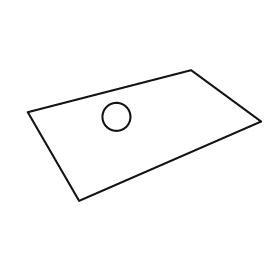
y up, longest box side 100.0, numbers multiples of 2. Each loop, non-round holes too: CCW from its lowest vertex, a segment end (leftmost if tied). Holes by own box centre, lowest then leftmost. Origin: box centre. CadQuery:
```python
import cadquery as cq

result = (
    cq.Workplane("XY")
    .moveTo(-28.0, -28.0)
    .lineTo(50.0, 6.0)
    .lineTo(20.0, 28.0)
    .lineTo(-50.0, 10.0)
    .close()
    .moveTo(-12.0, 8.0)
    .circle(6.0)
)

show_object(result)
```